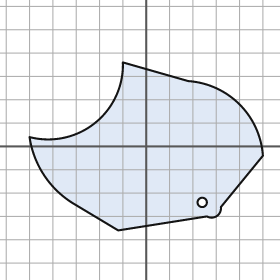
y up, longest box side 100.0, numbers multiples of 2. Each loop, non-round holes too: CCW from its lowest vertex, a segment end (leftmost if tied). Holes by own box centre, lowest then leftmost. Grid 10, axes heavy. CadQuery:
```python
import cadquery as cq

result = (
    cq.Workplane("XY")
    .moveTo(-12.0, -36.0)
    .lineTo(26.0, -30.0)
    .threePointArc((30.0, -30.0), (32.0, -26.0))
    .lineTo(50.0, -4.0)
    .threePointArc((40.0, 18.0), (18.0, 28.0))
    .lineTo(-10.0, 36.0)
    .threePointArc((-22.0, 10.0), (-50.0, 4.0))
    .threePointArc((-44.0, -12.0), (-32.0, -24.0))
    .close()
    .moveTo(24.0, -24.0)
    .circle(2.0)
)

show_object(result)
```